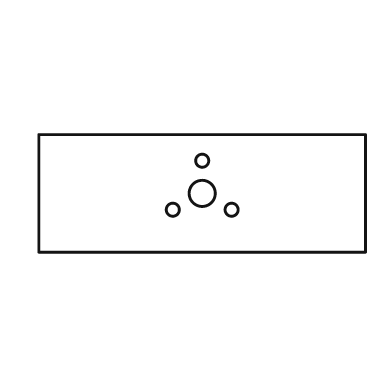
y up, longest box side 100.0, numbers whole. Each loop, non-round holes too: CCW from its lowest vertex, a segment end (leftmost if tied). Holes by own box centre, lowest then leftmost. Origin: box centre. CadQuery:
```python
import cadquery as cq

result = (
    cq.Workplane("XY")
    .moveTo(-50.0, -18.0)
    .lineTo(50.0, -18.0)
    .lineTo(50.0, 18.0)
    .lineTo(-50.0, 18.0)
    .close()
    .moveTo(-9.0, -5.0)
    .circle(2.0)
    .moveTo(9.0, -5.0)
    .circle(2.0)
    .moveTo(0.0, 0.0)
    .circle(4.0)
    .moveTo(0.0, 10.0)
    .circle(2.0)
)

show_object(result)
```